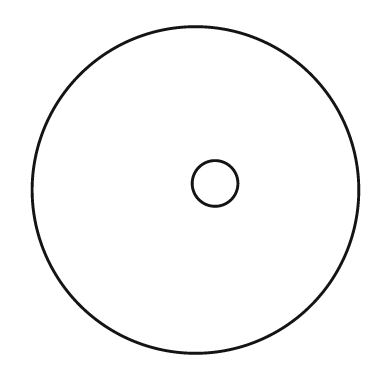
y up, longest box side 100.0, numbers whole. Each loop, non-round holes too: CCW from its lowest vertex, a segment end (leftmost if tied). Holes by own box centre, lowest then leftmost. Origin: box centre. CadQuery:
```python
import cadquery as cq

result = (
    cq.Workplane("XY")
    .moveTo(0.0, 0.0)
    .circle(50.0)
    .moveTo(6.0, 2.0)
    .circle(7.0)
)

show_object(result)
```